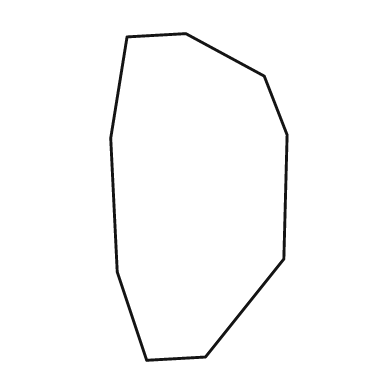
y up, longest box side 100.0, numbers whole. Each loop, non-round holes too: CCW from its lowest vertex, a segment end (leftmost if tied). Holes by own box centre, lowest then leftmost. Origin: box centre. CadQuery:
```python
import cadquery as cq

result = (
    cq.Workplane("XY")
    .moveTo(-16.0, -50.0)
    .lineTo(2.0, -49.0)
    .lineTo(26.0, -19.0)
    .lineTo(27.0, 19.0)
    .lineTo(20.0, 37.0)
    .lineTo(-4.0, 50.0)
    .lineTo(-22.0, 49.0)
    .lineTo(-27.0, 18.0)
    .lineTo(-25.0, -23.0)
    .close()
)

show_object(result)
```